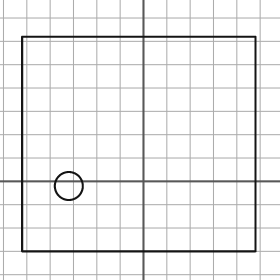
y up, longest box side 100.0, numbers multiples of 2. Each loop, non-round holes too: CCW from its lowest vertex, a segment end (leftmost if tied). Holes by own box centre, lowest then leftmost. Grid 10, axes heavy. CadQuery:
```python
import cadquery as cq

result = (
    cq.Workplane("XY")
    .moveTo(-52.0, -30.0)
    .lineTo(48.0, -30.0)
    .lineTo(48.0, 62.0)
    .lineTo(-52.0, 62.0)
    .close()
    .moveTo(-32.0, -2.0)
    .circle(6.0)
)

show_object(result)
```